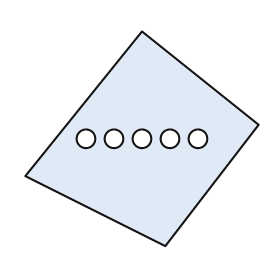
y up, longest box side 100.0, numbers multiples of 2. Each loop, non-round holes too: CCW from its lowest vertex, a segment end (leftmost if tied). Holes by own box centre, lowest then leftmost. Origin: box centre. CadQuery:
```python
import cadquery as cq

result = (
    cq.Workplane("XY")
    .moveTo(10.0, -46.0)
    .lineTo(50.0, 6.0)
    .lineTo(0.0, 46.0)
    .lineTo(-50.0, -16.0)
    .close()
    .moveTo(-24.0, 0.0)
    .circle(4.0)
    .moveTo(-12.0, 0.0)
    .circle(4.0)
    .moveTo(0.0, 0.0)
    .circle(4.0)
    .moveTo(12.0, 0.0)
    .circle(4.0)
    .moveTo(24.0, 0.0)
    .circle(4.0)
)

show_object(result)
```